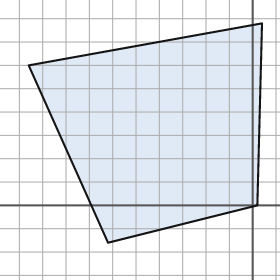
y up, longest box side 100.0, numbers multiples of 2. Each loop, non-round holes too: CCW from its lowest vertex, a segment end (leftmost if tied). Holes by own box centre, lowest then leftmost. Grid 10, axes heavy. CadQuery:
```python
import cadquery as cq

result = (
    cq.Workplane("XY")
    .moveTo(-62.0, -16.0)
    .lineTo(2.0, 0.0)
    .lineTo(4.0, 78.0)
    .lineTo(-96.0, 60.0)
    .close()
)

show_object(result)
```